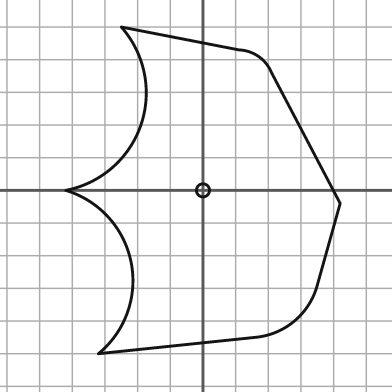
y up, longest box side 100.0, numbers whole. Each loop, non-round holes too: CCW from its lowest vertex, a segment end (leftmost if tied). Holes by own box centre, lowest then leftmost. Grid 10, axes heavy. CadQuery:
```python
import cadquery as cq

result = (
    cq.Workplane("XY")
    .moveTo(-32.0, -50.0)
    .lineTo(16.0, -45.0)
    .threePointArc((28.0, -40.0), (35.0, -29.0))
    .lineTo(42.0, -4.0)
    .lineTo(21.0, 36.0)
    .threePointArc((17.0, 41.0), (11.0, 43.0))
    .lineTo(-25.0, 50.0)
    .threePointArc((-19.0, 20.0), (-42.0, 0.0))
    .threePointArc((-22.0, -22.0), (-32.0, -50.0))
    .close()
    .moveTo(0.0, 0.0)
    .circle(2.0)
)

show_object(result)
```